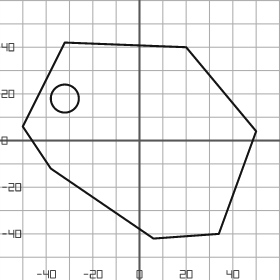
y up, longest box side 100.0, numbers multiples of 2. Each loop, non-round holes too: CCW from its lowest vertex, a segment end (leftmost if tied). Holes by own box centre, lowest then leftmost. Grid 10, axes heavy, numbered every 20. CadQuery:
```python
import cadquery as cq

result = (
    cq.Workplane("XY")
    .moveTo(6.0, -42.0)
    .lineTo(34.0, -40.0)
    .lineTo(50.0, 4.0)
    .lineTo(20.0, 40.0)
    .lineTo(-32.0, 42.0)
    .lineTo(-50.0, 6.0)
    .lineTo(-38.0, -12.0)
    .close()
    .moveTo(-32.0, 18.0)
    .circle(6.0)
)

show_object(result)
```